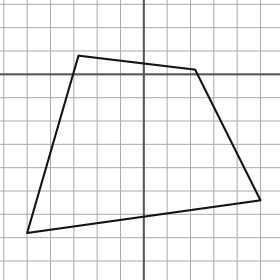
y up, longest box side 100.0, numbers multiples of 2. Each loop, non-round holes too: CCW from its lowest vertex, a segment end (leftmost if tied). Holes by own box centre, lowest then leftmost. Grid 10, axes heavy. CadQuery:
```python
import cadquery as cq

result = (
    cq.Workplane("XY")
    .moveTo(-50.0, -68.0)
    .lineTo(50.0, -54.0)
    .lineTo(22.0, 2.0)
    .lineTo(-28.0, 8.0)
    .close()
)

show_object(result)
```